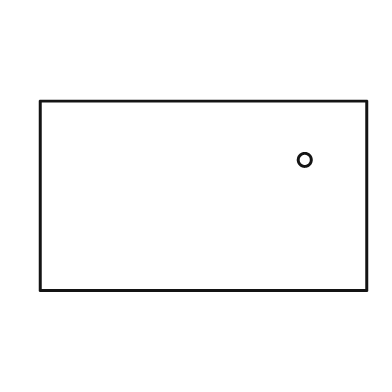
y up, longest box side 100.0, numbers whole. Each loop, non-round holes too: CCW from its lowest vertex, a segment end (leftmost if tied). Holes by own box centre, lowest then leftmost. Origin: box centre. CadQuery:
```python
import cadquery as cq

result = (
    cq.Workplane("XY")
    .moveTo(-50.0, -29.0)
    .lineTo(50.0, -29.0)
    .lineTo(50.0, 29.0)
    .lineTo(-50.0, 29.0)
    .close()
    .moveTo(31.0, 11.0)
    .circle(2.0)
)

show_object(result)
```